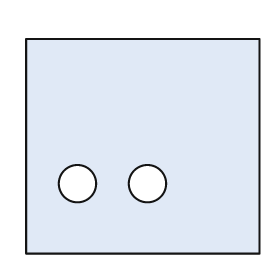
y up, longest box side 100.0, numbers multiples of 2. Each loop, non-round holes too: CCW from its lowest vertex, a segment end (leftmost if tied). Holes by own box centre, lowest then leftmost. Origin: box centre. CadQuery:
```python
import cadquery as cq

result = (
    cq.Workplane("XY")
    .moveTo(-50.0, -46.0)
    .lineTo(50.0, -46.0)
    .lineTo(50.0, 46.0)
    .lineTo(-50.0, 46.0)
    .close()
    .moveTo(-28.0, -16.0)
    .circle(8.0)
    .moveTo(2.0, -16.0)
    .circle(8.0)
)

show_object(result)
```